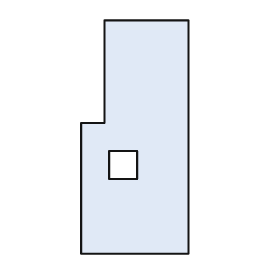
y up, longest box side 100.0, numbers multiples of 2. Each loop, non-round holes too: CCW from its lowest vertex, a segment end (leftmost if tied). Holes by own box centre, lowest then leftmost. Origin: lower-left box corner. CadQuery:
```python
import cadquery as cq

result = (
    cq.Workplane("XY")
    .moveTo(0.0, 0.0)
    .lineTo(46.0, 0.0)
    .lineTo(46.0, 100.0)
    .lineTo(10.0, 100.0)
    .lineTo(10.0, 56.0)
    .lineTo(0.0, 56.0)
    .close()
    .moveTo(12.0, 32.0)
    .lineTo(24.0, 32.0)
    .lineTo(24.0, 44.0)
    .lineTo(12.0, 44.0)
    .close()
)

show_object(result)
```